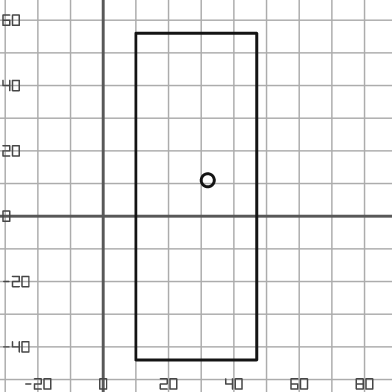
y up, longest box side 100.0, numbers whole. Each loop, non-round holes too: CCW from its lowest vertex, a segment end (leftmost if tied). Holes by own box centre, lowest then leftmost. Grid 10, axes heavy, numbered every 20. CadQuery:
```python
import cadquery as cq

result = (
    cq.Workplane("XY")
    .moveTo(10.0, -44.0)
    .lineTo(47.0, -44.0)
    .lineTo(47.0, 56.0)
    .lineTo(10.0, 56.0)
    .close()
    .moveTo(32.0, 11.0)
    .circle(2.0)
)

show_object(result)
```